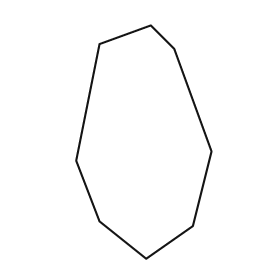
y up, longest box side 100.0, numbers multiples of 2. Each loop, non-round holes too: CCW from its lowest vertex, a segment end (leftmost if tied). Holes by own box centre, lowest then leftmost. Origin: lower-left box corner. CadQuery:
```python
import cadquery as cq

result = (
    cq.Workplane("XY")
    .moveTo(30.0, 0.0)
    .lineTo(50.0, 14.0)
    .lineTo(58.0, 46.0)
    .lineTo(42.0, 90.0)
    .lineTo(32.0, 100.0)
    .lineTo(10.0, 92.0)
    .lineTo(0.0, 42.0)
    .lineTo(10.0, 16.0)
    .close()
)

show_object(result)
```